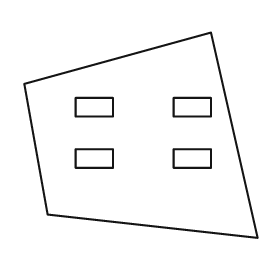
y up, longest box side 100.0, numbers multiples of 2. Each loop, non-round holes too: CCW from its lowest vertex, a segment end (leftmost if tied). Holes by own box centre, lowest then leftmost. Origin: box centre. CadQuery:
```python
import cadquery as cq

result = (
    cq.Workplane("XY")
    .moveTo(50.0, -44.0)
    .lineTo(30.0, 44.0)
    .lineTo(-50.0, 22.0)
    .lineTo(-40.0, -34.0)
    .close()
    .moveTo(-28.0, -14.0)
    .lineTo(-12.0, -14.0)
    .lineTo(-12.0, -6.0)
    .lineTo(-28.0, -6.0)
    .close()
    .moveTo(14.0, -14.0)
    .lineTo(30.0, -14.0)
    .lineTo(30.0, -6.0)
    .lineTo(14.0, -6.0)
    .close()
    .moveTo(-28.0, 8.0)
    .lineTo(-12.0, 8.0)
    .lineTo(-12.0, 16.0)
    .lineTo(-28.0, 16.0)
    .close()
    .moveTo(14.0, 8.0)
    .lineTo(30.0, 8.0)
    .lineTo(30.0, 16.0)
    .lineTo(14.0, 16.0)
    .close()
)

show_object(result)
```